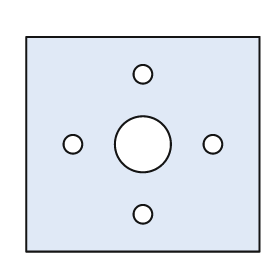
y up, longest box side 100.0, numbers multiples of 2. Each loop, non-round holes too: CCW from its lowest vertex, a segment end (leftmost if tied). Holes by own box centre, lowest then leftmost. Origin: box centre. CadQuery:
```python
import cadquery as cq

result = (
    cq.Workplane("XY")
    .moveTo(-50.0, -46.0)
    .lineTo(50.0, -46.0)
    .lineTo(50.0, 46.0)
    .lineTo(-50.0, 46.0)
    .close()
    .moveTo(0.0, -30.0)
    .circle(4.0)
    .moveTo(-30.0, 0.0)
    .circle(4.0)
    .moveTo(0.0, 0.0)
    .circle(12.0)
    .moveTo(30.0, 0.0)
    .circle(4.0)
    .moveTo(0.0, 30.0)
    .circle(4.0)
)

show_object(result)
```